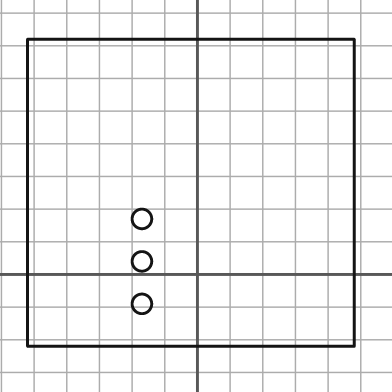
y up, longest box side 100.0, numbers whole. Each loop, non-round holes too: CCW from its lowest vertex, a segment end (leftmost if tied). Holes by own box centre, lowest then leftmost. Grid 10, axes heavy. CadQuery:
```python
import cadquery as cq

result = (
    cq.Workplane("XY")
    .moveTo(-52.0, -22.0)
    .lineTo(48.0, -22.0)
    .lineTo(48.0, 72.0)
    .lineTo(-52.0, 72.0)
    .close()
    .moveTo(-17.0, -9.0)
    .circle(3.0)
    .moveTo(-17.0, 4.0)
    .circle(3.0)
    .moveTo(-17.0, 17.0)
    .circle(3.0)
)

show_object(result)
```